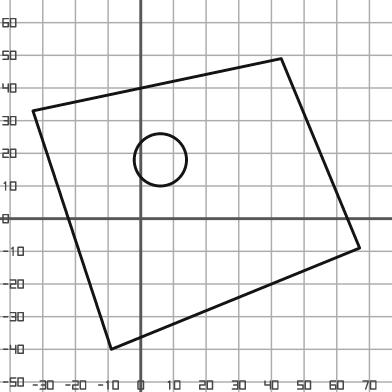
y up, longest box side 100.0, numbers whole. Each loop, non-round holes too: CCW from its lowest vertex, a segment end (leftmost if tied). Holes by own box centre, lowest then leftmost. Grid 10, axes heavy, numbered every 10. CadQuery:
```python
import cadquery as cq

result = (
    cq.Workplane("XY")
    .moveTo(-9.0, -40.0)
    .lineTo(67.0, -9.0)
    .lineTo(43.0, 49.0)
    .lineTo(-33.0, 33.0)
    .close()
    .moveTo(6.0, 18.0)
    .circle(8.0)
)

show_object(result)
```